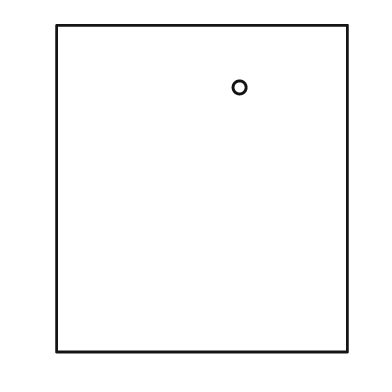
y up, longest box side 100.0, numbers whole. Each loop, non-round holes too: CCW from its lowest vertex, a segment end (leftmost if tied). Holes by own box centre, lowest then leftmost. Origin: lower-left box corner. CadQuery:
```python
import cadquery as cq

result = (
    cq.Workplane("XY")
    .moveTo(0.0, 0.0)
    .lineTo(89.0, 0.0)
    .lineTo(89.0, 100.0)
    .lineTo(0.0, 100.0)
    .close()
    .moveTo(56.0, 81.0)
    .circle(2.0)
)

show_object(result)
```